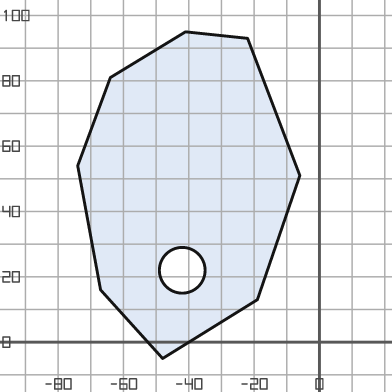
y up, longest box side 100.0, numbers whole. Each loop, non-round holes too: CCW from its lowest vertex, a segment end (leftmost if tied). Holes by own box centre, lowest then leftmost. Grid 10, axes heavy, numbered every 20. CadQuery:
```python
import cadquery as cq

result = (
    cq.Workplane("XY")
    .moveTo(-48.0, -5.0)
    .lineTo(-19.0, 13.0)
    .lineTo(-6.0, 51.0)
    .lineTo(-22.0, 93.0)
    .lineTo(-41.0, 95.0)
    .lineTo(-64.0, 81.0)
    .lineTo(-74.0, 54.0)
    .lineTo(-67.0, 16.0)
    .close()
    .moveTo(-42.0, 22.0)
    .circle(7.0)
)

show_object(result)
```